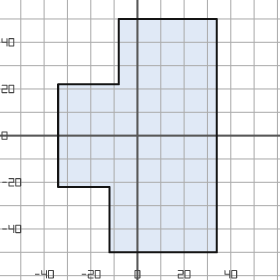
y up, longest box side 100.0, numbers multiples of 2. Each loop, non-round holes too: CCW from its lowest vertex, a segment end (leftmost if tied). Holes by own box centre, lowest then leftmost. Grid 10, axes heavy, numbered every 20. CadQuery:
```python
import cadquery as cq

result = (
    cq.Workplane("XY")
    .moveTo(-12.0, -50.0)
    .lineTo(34.0, -50.0)
    .lineTo(34.0, 50.0)
    .lineTo(-8.0, 50.0)
    .lineTo(-8.0, 22.0)
    .lineTo(-34.0, 22.0)
    .lineTo(-34.0, -22.0)
    .lineTo(-12.0, -22.0)
    .close()
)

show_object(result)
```